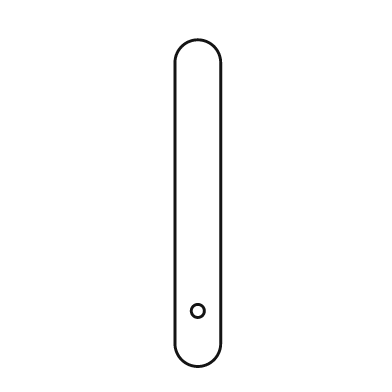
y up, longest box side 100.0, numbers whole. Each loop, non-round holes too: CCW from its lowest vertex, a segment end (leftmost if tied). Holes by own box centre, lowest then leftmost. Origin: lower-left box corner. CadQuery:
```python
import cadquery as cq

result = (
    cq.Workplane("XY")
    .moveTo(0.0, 7.0)
    .threePointArc((7.0, 0.0), (14.0, 7.0))
    .lineTo(14.0, 93.0)
    .threePointArc((7.0, 100.0), (0.0, 93.0))
    .close()
    .moveTo(7.0, 17.0)
    .circle(2.0)
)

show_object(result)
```